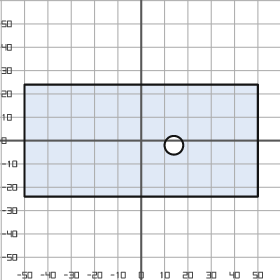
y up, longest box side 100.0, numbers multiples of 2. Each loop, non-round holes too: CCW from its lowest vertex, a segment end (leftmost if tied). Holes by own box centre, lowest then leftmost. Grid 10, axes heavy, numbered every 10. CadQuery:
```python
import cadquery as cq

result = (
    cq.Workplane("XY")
    .moveTo(-50.0, -24.0)
    .lineTo(50.0, -24.0)
    .lineTo(50.0, 24.0)
    .lineTo(-50.0, 24.0)
    .close()
    .moveTo(14.0, -2.0)
    .circle(4.0)
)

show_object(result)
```